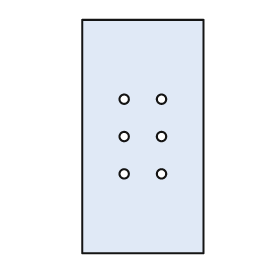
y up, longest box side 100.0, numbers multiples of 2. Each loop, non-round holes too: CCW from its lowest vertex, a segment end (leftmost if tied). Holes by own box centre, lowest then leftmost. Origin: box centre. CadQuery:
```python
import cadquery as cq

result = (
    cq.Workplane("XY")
    .moveTo(-26.0, -50.0)
    .lineTo(26.0, -50.0)
    .lineTo(26.0, 50.0)
    .lineTo(-26.0, 50.0)
    .close()
    .moveTo(-8.0, -16.0)
    .circle(2.0)
    .moveTo(8.0, -16.0)
    .circle(2.0)
    .moveTo(-8.0, 0.0)
    .circle(2.0)
    .moveTo(8.0, 0.0)
    .circle(2.0)
    .moveTo(-8.0, 16.0)
    .circle(2.0)
    .moveTo(8.0, 16.0)
    .circle(2.0)
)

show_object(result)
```